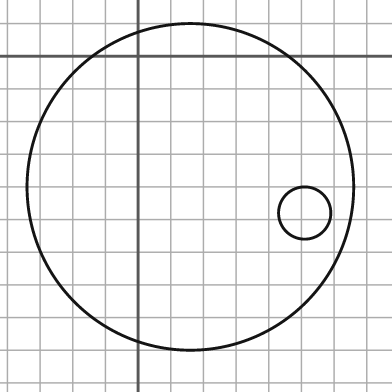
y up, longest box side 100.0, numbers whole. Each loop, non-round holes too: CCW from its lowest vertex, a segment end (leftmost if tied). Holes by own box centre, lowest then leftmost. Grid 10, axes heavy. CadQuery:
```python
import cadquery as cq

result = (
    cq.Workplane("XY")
    .moveTo(16.0, -40.0)
    .circle(50.0)
    .moveTo(51.0, -48.0)
    .circle(8.0)
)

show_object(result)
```